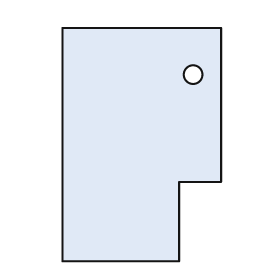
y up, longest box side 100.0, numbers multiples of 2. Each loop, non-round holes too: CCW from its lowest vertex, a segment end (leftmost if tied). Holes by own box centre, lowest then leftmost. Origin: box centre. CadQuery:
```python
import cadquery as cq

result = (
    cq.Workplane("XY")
    .moveTo(-34.0, -50.0)
    .lineTo(16.0, -50.0)
    .lineTo(16.0, -16.0)
    .lineTo(34.0, -16.0)
    .lineTo(34.0, 50.0)
    .lineTo(-34.0, 50.0)
    .close()
    .moveTo(22.0, 30.0)
    .circle(4.0)
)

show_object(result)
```